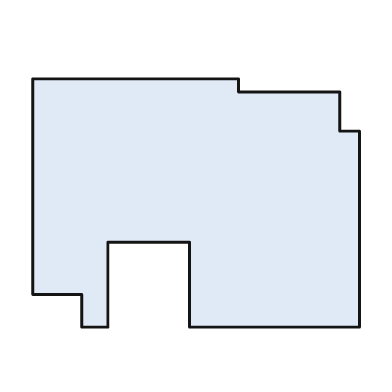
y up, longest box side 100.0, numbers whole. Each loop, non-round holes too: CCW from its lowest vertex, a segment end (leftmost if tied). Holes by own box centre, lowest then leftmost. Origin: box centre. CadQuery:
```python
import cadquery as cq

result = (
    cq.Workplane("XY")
    .moveTo(-35.0, -38.0)
    .lineTo(-27.0, -38.0)
    .lineTo(-27.0, -12.0)
    .lineTo(-2.0, -12.0)
    .lineTo(-2.0, -38.0)
    .lineTo(50.0, -38.0)
    .lineTo(50.0, 22.0)
    .lineTo(44.0, 22.0)
    .lineTo(44.0, 34.0)
    .lineTo(13.0, 34.0)
    .lineTo(13.0, 38.0)
    .lineTo(-50.0, 38.0)
    .lineTo(-50.0, -28.0)
    .lineTo(-35.0, -28.0)
    .close()
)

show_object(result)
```